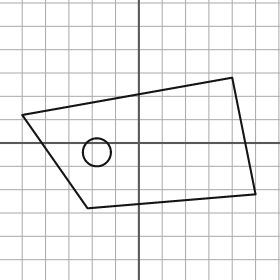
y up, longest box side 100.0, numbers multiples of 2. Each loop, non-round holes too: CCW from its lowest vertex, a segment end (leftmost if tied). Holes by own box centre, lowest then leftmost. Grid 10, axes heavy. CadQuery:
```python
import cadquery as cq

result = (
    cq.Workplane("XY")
    .moveTo(-22.0, -28.0)
    .lineTo(50.0, -22.0)
    .lineTo(40.0, 28.0)
    .lineTo(-50.0, 12.0)
    .close()
    .moveTo(-18.0, -4.0)
    .circle(6.0)
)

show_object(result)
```